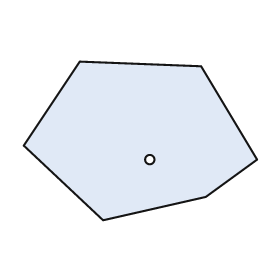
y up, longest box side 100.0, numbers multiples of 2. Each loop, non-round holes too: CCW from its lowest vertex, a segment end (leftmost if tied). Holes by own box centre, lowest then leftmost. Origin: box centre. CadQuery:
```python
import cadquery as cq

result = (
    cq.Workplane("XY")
    .moveTo(-16.0, -34.0)
    .lineTo(28.0, -24.0)
    .lineTo(50.0, -8.0)
    .lineTo(26.0, 32.0)
    .lineTo(-26.0, 34.0)
    .lineTo(-50.0, -2.0)
    .close()
    .moveTo(4.0, -8.0)
    .circle(2.0)
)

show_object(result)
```